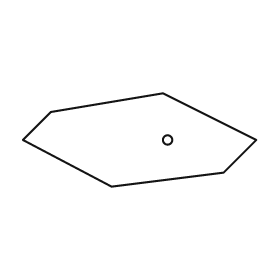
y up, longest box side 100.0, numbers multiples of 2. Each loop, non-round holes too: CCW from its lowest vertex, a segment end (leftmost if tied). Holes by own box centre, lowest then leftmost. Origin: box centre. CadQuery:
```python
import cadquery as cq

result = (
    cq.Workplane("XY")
    .moveTo(-12.0, -20.0)
    .lineTo(36.0, -14.0)
    .lineTo(50.0, 0.0)
    .lineTo(10.0, 20.0)
    .lineTo(-38.0, 12.0)
    .lineTo(-50.0, 0.0)
    .close()
    .moveTo(12.0, 0.0)
    .circle(2.0)
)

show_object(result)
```